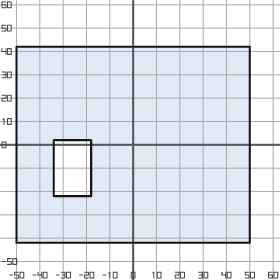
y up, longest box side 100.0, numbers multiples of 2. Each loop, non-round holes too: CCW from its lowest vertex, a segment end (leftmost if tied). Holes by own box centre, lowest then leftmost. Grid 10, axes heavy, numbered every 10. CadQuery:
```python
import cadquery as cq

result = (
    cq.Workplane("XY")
    .moveTo(-50.0, -42.0)
    .lineTo(50.0, -42.0)
    .lineTo(50.0, 42.0)
    .lineTo(-50.0, 42.0)
    .close()
    .moveTo(-34.0, -22.0)
    .lineTo(-18.0, -22.0)
    .lineTo(-18.0, 2.0)
    .lineTo(-34.0, 2.0)
    .close()
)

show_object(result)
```